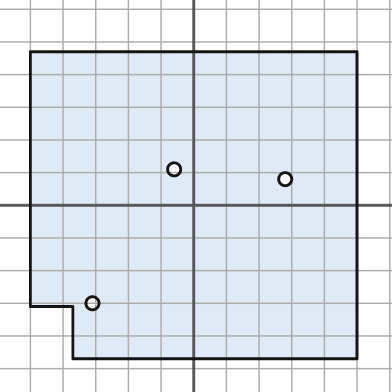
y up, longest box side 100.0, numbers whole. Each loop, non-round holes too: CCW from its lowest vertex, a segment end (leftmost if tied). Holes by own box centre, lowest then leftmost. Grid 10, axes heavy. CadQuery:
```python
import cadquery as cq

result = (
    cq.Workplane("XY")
    .moveTo(-37.0, -47.0)
    .lineTo(50.0, -47.0)
    .lineTo(50.0, 47.0)
    .lineTo(-50.0, 47.0)
    .lineTo(-50.0, -31.0)
    .lineTo(-37.0, -31.0)
    .close()
    .moveTo(-31.0, -30.0)
    .circle(2.0)
    .moveTo(28.0, 8.0)
    .circle(2.0)
    .moveTo(-6.0, 11.0)
    .circle(2.0)
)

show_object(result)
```